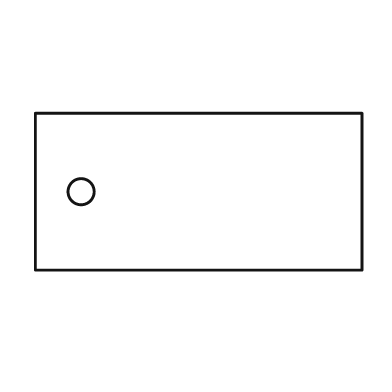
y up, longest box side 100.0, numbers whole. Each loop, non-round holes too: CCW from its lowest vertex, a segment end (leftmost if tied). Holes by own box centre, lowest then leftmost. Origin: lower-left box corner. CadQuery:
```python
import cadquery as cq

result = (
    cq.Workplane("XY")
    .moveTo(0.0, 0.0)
    .lineTo(100.0, 0.0)
    .lineTo(100.0, 48.0)
    .lineTo(0.0, 48.0)
    .close()
    .moveTo(14.0, 24.0)
    .circle(4.0)
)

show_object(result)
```